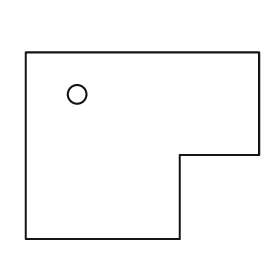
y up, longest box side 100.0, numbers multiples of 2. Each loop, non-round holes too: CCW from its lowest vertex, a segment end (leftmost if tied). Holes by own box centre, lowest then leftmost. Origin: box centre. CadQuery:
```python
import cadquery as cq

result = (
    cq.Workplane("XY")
    .moveTo(-50.0, -40.0)
    .lineTo(16.0, -40.0)
    .lineTo(16.0, -4.0)
    .lineTo(50.0, -4.0)
    .lineTo(50.0, 40.0)
    .lineTo(-50.0, 40.0)
    .close()
    .moveTo(-28.0, 22.0)
    .circle(4.0)
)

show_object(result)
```